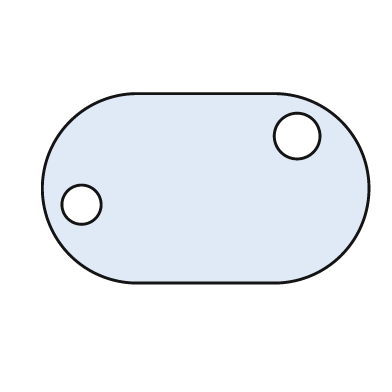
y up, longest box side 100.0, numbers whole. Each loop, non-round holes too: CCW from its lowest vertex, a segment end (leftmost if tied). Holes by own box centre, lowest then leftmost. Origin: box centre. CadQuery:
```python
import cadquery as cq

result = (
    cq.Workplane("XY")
    .moveTo(-21.0, -29.0)
    .lineTo(21.0, -29.0)
    .threePointArc((50.0, 0.0), (21.0, 29.0))
    .lineTo(-21.0, 29.0)
    .threePointArc((-50.0, 0.0), (-21.0, -29.0))
    .close()
    .moveTo(-38.0, -5.0)
    .circle(6.0)
    .moveTo(28.0, 16.0)
    .circle(7.0)
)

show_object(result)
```